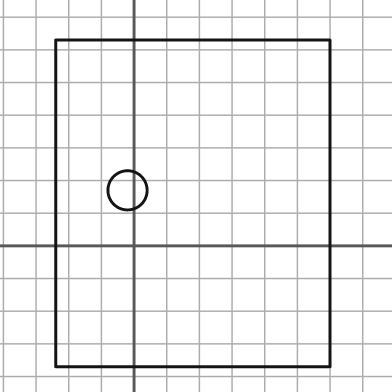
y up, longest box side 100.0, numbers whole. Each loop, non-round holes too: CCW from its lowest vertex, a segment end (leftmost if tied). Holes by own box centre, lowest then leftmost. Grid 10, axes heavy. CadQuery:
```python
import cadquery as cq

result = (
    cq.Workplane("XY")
    .moveTo(-24.0, -37.0)
    .lineTo(60.0, -37.0)
    .lineTo(60.0, 63.0)
    .lineTo(-24.0, 63.0)
    .close()
    .moveTo(-2.0, 17.0)
    .circle(6.0)
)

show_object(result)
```